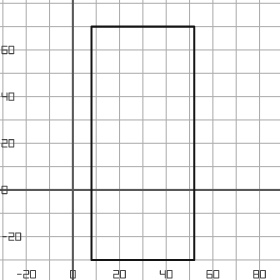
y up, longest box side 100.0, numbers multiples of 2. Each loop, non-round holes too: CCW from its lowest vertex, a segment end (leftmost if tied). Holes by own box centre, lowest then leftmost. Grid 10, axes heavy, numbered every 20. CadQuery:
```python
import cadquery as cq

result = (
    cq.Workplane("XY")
    .moveTo(8.0, -30.0)
    .lineTo(52.0, -30.0)
    .lineTo(52.0, 70.0)
    .lineTo(8.0, 70.0)
    .close()
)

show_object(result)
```